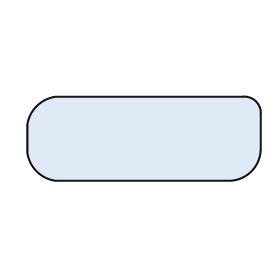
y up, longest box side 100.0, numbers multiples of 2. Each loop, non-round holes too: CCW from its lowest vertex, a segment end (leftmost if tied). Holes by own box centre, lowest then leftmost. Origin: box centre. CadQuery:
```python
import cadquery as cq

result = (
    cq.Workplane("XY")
    .moveTo(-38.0, -18.0)
    .lineTo(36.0, -18.0)
    .threePointArc((46.0, -14.0), (50.0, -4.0))
    .lineTo(50.0, 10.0)
    .threePointArc((48.0, 16.0), (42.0, 18.0))
    .lineTo(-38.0, 18.0)
    .threePointArc((-46.0, 14.0), (-50.0, 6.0))
    .lineTo(-50.0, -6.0)
    .threePointArc((-46.0, -14.0), (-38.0, -18.0))
    .close()
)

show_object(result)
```